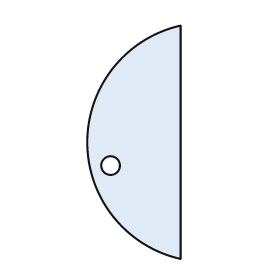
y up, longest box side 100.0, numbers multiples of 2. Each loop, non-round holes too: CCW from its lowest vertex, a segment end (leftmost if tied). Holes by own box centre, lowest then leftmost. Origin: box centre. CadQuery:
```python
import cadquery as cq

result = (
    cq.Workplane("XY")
    .moveTo(20.0, -50.0)
    .lineTo(20.0, 50.0)
    .threePointArc((-20.0, 0.0), (20.0, -50.0))
    .close()
    .moveTo(-10.0, -10.0)
    .circle(4.0)
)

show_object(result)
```